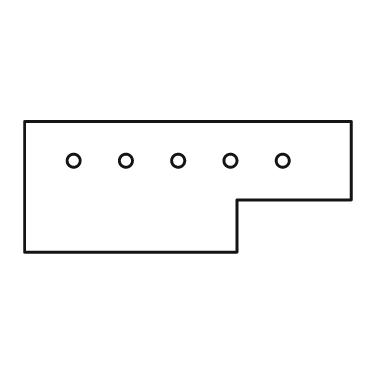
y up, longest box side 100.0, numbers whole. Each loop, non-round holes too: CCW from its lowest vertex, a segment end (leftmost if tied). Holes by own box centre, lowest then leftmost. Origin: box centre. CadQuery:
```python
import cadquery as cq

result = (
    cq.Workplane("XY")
    .moveTo(-50.0, -20.0)
    .lineTo(15.0, -20.0)
    .lineTo(15.0, -4.0)
    .lineTo(50.0, -4.0)
    .lineTo(50.0, 20.0)
    .lineTo(-50.0, 20.0)
    .close()
    .moveTo(-35.0, 8.0)
    .circle(2.0)
    .moveTo(-19.0, 8.0)
    .circle(2.0)
    .moveTo(-3.0, 8.0)
    .circle(2.0)
    .moveTo(13.0, 8.0)
    .circle(2.0)
    .moveTo(29.0, 8.0)
    .circle(2.0)
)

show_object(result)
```